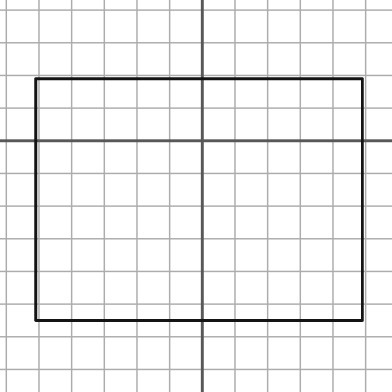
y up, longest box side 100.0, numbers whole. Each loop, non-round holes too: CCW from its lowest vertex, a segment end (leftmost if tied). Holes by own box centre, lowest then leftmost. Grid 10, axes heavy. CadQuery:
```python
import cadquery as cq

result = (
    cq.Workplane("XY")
    .moveTo(-51.0, -55.0)
    .lineTo(49.0, -55.0)
    .lineTo(49.0, 19.0)
    .lineTo(-51.0, 19.0)
    .close()
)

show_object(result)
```